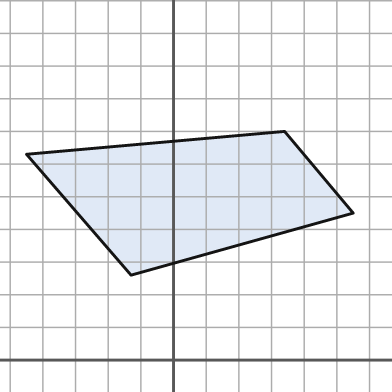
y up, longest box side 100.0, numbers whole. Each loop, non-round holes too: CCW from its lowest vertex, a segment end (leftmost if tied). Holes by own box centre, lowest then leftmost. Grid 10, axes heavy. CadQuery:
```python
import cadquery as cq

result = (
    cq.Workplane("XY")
    .moveTo(-13.0, 26.0)
    .lineTo(55.0, 45.0)
    .lineTo(34.0, 70.0)
    .lineTo(-45.0, 63.0)
    .close()
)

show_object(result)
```